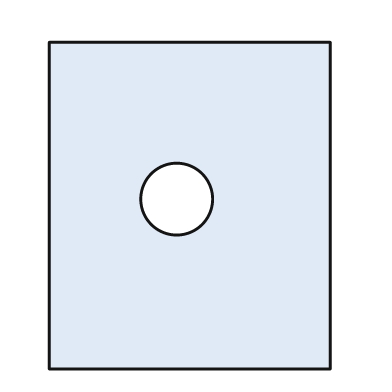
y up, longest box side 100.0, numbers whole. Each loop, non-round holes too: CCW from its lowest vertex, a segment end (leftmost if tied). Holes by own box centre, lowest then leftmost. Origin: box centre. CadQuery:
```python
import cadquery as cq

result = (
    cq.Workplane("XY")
    .moveTo(-43.0, -50.0)
    .lineTo(43.0, -50.0)
    .lineTo(43.0, 50.0)
    .lineTo(-43.0, 50.0)
    .close()
    .moveTo(-4.0, 2.0)
    .circle(11.0)
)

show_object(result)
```